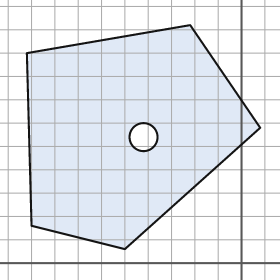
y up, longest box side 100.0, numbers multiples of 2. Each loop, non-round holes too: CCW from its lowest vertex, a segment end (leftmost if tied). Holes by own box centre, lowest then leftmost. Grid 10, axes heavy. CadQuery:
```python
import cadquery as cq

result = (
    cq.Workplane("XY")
    .moveTo(-50.0, 6.0)
    .lineTo(8.0, 58.0)
    .lineTo(-22.0, 102.0)
    .lineTo(-92.0, 90.0)
    .lineTo(-90.0, 16.0)
    .close()
    .moveTo(-42.0, 54.0)
    .circle(6.0)
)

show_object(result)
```